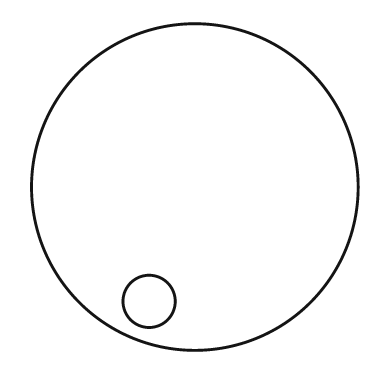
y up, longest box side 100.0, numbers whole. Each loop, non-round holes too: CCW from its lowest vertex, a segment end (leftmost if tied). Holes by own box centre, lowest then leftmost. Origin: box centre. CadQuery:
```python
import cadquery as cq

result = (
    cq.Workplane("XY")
    .moveTo(0.0, 0.0)
    .circle(50.0)
    .moveTo(-14.0, -35.0)
    .circle(8.0)
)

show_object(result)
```